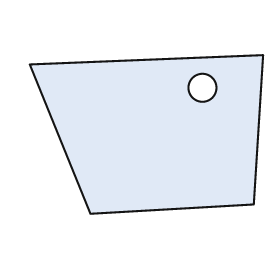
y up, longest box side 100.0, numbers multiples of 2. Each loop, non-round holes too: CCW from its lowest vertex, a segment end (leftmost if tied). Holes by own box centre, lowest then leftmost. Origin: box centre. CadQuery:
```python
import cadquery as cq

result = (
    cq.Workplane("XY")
    .moveTo(-24.0, -34.0)
    .lineTo(46.0, -30.0)
    .lineTo(50.0, 34.0)
    .lineTo(-50.0, 30.0)
    .close()
    .moveTo(24.0, 20.0)
    .circle(6.0)
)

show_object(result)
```